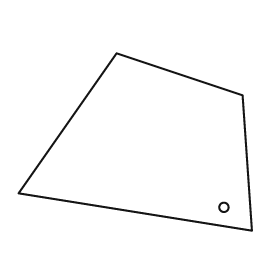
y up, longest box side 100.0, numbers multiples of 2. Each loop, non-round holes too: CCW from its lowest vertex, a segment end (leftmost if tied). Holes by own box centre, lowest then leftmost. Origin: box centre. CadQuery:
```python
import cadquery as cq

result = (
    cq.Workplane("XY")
    .moveTo(50.0, -38.0)
    .lineTo(46.0, 20.0)
    .lineTo(-8.0, 38.0)
    .lineTo(-50.0, -22.0)
    .close()
    .moveTo(38.0, -28.0)
    .circle(2.0)
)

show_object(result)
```